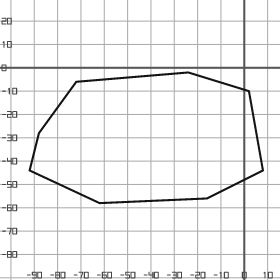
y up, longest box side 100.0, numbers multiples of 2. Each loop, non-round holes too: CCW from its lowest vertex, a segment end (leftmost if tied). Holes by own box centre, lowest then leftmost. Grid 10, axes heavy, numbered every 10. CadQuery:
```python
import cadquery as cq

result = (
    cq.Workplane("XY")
    .moveTo(-62.0, -58.0)
    .lineTo(-16.0, -56.0)
    .lineTo(8.0, -44.0)
    .lineTo(2.0, -10.0)
    .lineTo(-24.0, -2.0)
    .lineTo(-72.0, -6.0)
    .lineTo(-88.0, -28.0)
    .lineTo(-92.0, -44.0)
    .close()
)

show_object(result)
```